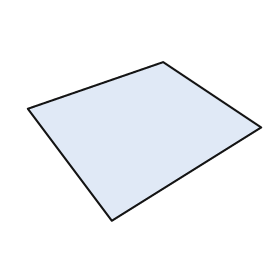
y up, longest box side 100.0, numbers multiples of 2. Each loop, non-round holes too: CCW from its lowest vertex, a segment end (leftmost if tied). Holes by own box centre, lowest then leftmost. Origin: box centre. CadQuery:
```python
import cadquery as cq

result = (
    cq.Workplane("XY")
    .moveTo(-14.0, -34.0)
    .lineTo(50.0, 6.0)
    .lineTo(8.0, 34.0)
    .lineTo(-50.0, 14.0)
    .close()
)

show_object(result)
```